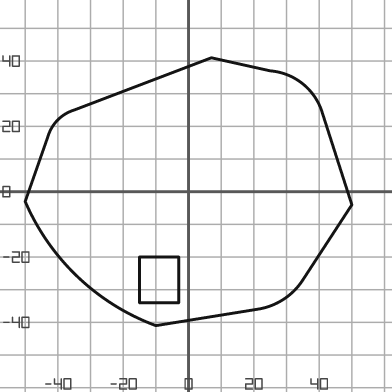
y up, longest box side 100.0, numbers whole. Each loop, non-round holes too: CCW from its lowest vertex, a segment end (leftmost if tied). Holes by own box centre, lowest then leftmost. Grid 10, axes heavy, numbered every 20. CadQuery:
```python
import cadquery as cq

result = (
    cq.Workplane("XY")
    .moveTo(-10.0, -41.0)
    .lineTo(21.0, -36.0)
    .threePointArc((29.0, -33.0), (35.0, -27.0))
    .lineTo(50.0, -4.0)
    .lineTo(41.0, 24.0)
    .threePointArc((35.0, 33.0), (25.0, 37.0))
    .lineTo(7.0, 41.0)
    .lineTo(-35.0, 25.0)
    .threePointArc((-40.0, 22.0), (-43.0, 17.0))
    .lineTo(-50.0, -3.0)
    .threePointArc((-34.0, -26.0), (-10.0, -41.0))
    .close()
    .moveTo(-15.0, -34.0)
    .lineTo(-3.0, -34.0)
    .lineTo(-3.0, -20.0)
    .lineTo(-15.0, -20.0)
    .close()
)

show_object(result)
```